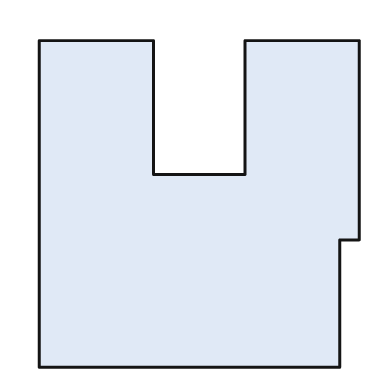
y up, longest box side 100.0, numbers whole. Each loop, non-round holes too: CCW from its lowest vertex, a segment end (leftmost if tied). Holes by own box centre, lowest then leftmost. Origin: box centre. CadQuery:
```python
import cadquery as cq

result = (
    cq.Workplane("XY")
    .moveTo(-49.0, -50.0)
    .lineTo(43.0, -50.0)
    .lineTo(43.0, -11.0)
    .lineTo(49.0, -11.0)
    .lineTo(49.0, 50.0)
    .lineTo(14.0, 50.0)
    .lineTo(14.0, 9.0)
    .lineTo(-14.0, 9.0)
    .lineTo(-14.0, 50.0)
    .lineTo(-49.0, 50.0)
    .close()
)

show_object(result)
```